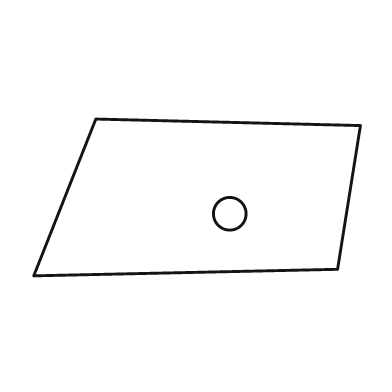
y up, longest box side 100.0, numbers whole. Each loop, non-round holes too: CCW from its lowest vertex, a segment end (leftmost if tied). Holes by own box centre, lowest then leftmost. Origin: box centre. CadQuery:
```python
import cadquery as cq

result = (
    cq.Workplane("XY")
    .moveTo(-50.0, -24.0)
    .lineTo(43.0, -22.0)
    .lineTo(50.0, 22.0)
    .lineTo(-31.0, 24.0)
    .close()
    .moveTo(10.0, -5.0)
    .circle(5.0)
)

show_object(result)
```